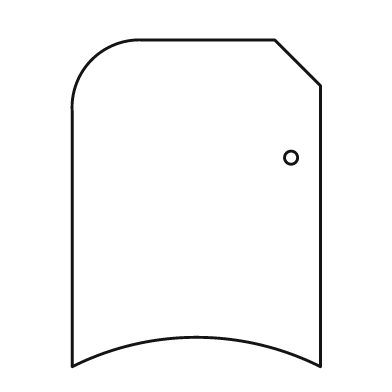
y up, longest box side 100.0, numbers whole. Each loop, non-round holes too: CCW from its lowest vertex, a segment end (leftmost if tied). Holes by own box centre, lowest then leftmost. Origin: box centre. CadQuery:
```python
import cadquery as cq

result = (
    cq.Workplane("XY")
    .moveTo(-38.0, -50.0)
    .threePointArc((0.0, -41.0), (38.0, -50.0))
    .lineTo(38.0, 36.0)
    .lineTo(24.0, 50.0)
    .lineTo(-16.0, 50.0)
    .threePointArc((-32.0, 44.0), (-38.0, 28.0))
    .close()
    .moveTo(29.0, 14.0)
    .circle(2.0)
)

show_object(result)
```